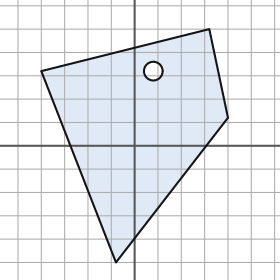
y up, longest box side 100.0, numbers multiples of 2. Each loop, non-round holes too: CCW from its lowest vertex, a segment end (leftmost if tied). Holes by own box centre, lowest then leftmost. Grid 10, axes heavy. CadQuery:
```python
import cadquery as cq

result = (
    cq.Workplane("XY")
    .moveTo(-8.0, -50.0)
    .lineTo(40.0, 12.0)
    .lineTo(32.0, 50.0)
    .lineTo(-40.0, 32.0)
    .close()
    .moveTo(8.0, 32.0)
    .circle(4.0)
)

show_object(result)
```